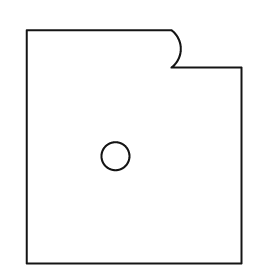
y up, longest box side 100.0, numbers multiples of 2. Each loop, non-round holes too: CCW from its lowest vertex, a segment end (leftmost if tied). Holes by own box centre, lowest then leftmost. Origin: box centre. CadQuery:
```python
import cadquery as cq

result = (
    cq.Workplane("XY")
    .moveTo(-46.0, -50.0)
    .lineTo(46.0, -50.0)
    .lineTo(46.0, 34.0)
    .lineTo(16.0, 34.0)
    .threePointArc((20.0, 42.0), (16.0, 50.0))
    .lineTo(-46.0, 50.0)
    .close()
    .moveTo(-8.0, -4.0)
    .circle(6.0)
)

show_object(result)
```